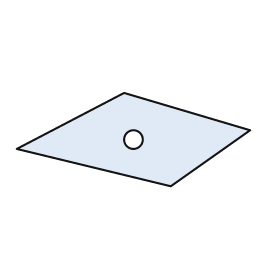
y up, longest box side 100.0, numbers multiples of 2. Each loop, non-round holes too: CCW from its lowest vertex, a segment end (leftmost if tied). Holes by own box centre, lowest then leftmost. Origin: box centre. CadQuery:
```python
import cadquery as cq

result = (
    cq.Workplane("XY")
    .moveTo(16.0, -20.0)
    .lineTo(50.0, 4.0)
    .lineTo(-4.0, 20.0)
    .lineTo(-50.0, -4.0)
    .close()
    .moveTo(0.0, 0.0)
    .circle(4.0)
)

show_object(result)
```